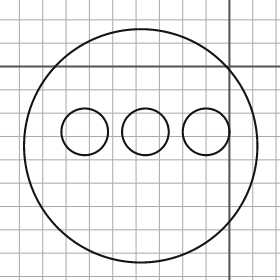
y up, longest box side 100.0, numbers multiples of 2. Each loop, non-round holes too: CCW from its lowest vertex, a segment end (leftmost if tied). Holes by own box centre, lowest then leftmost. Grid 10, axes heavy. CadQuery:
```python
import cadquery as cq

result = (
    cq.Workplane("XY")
    .moveTo(-38.0, -34.0)
    .circle(50.0)
    .moveTo(-62.0, -28.0)
    .circle(10.0)
    .moveTo(-36.0, -28.0)
    .circle(10.0)
    .moveTo(-10.0, -28.0)
    .circle(10.0)
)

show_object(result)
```